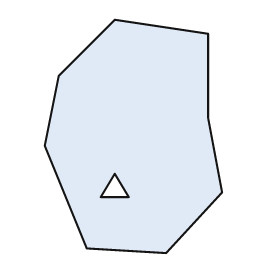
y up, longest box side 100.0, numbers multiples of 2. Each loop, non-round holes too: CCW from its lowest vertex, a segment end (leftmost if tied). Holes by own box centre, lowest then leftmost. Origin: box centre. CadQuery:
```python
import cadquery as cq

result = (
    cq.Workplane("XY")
    .moveTo(14.0, -50.0)
    .lineTo(38.0, -24.0)
    .lineTo(32.0, 8.0)
    .lineTo(32.0, 44.0)
    .lineTo(-8.0, 50.0)
    .lineTo(-32.0, 26.0)
    .lineTo(-38.0, -4.0)
    .lineTo(-20.0, -48.0)
    .close()
    .moveTo(-14.0, -26.0)
    .lineTo(-2.0, -26.0)
    .lineTo(-8.0, -16.0)
    .close()
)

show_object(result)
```